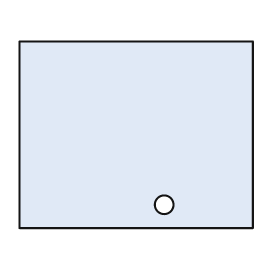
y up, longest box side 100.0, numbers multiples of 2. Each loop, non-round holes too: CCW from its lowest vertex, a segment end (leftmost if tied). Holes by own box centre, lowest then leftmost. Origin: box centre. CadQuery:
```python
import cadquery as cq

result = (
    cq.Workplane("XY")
    .moveTo(-50.0, -40.0)
    .lineTo(50.0, -40.0)
    .lineTo(50.0, 40.0)
    .lineTo(-50.0, 40.0)
    .close()
    .moveTo(12.0, -30.0)
    .circle(4.0)
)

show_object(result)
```